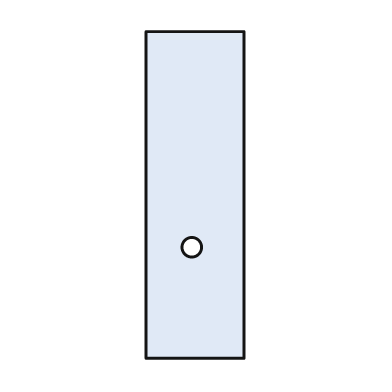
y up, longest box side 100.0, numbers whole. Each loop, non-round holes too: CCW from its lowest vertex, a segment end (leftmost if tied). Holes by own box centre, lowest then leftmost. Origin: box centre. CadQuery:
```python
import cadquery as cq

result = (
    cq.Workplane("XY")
    .moveTo(-15.0, -50.0)
    .lineTo(15.0, -50.0)
    .lineTo(15.0, 50.0)
    .lineTo(-15.0, 50.0)
    .close()
    .moveTo(-1.0, -16.0)
    .circle(3.0)
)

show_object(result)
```